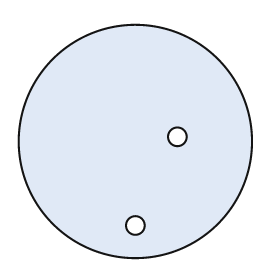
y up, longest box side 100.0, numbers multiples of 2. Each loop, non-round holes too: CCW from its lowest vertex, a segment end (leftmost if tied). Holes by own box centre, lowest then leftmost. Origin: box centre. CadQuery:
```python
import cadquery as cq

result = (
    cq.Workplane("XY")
    .moveTo(0.0, 0.0)
    .circle(50.0)
    .moveTo(0.0, -36.0)
    .circle(4.0)
    .moveTo(18.0, 2.0)
    .circle(4.0)
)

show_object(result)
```